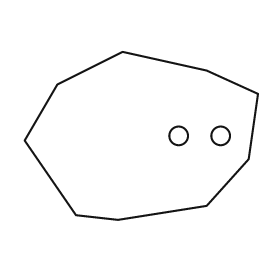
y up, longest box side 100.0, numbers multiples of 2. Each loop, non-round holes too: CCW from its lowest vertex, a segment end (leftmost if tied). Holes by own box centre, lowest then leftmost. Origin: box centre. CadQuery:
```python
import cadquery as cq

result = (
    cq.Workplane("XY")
    .moveTo(-10.0, -36.0)
    .lineTo(28.0, -30.0)
    .lineTo(46.0, -10.0)
    .lineTo(50.0, 18.0)
    .lineTo(28.0, 28.0)
    .lineTo(-8.0, 36.0)
    .lineTo(-36.0, 22.0)
    .lineTo(-50.0, -2.0)
    .lineTo(-28.0, -34.0)
    .close()
    .moveTo(16.0, 0.0)
    .circle(4.0)
    .moveTo(34.0, 0.0)
    .circle(4.0)
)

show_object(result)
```